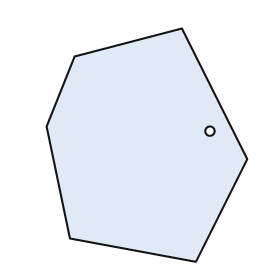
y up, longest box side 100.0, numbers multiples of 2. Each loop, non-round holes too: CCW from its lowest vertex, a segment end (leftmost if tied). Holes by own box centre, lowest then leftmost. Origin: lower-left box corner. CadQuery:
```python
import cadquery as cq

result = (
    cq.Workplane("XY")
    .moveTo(64.0, 0.0)
    .lineTo(86.0, 44.0)
    .lineTo(58.0, 100.0)
    .lineTo(12.0, 88.0)
    .lineTo(0.0, 58.0)
    .lineTo(10.0, 10.0)
    .close()
    .moveTo(70.0, 56.0)
    .circle(2.0)
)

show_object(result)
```